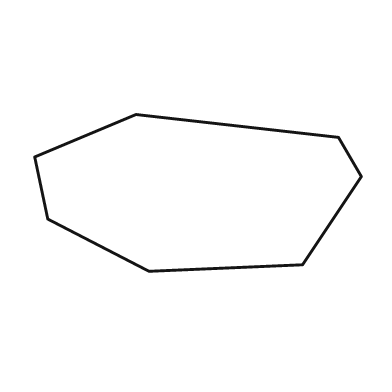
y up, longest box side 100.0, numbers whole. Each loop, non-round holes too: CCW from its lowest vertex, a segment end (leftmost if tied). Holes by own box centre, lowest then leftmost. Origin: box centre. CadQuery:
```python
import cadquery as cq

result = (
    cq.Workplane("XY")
    .moveTo(-15.0, -24.0)
    .lineTo(32.0, -22.0)
    .lineTo(50.0, 5.0)
    .lineTo(43.0, 17.0)
    .lineTo(-19.0, 24.0)
    .lineTo(-50.0, 11.0)
    .lineTo(-46.0, -8.0)
    .close()
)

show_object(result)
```